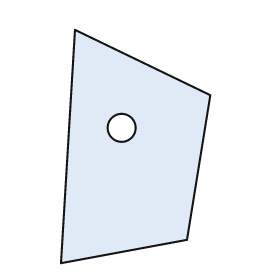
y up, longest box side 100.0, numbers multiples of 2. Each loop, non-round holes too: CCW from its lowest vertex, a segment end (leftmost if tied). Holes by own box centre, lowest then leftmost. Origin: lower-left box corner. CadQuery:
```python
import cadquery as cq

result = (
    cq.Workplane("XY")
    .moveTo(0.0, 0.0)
    .lineTo(54.0, 10.0)
    .lineTo(64.0, 72.0)
    .lineTo(6.0, 100.0)
    .close()
    .moveTo(26.0, 58.0)
    .circle(6.0)
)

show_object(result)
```